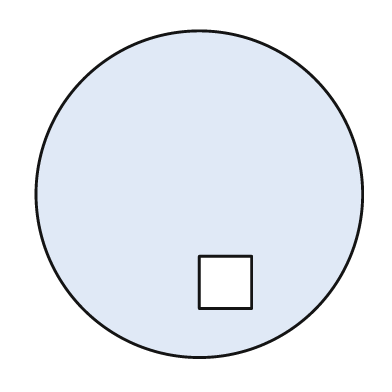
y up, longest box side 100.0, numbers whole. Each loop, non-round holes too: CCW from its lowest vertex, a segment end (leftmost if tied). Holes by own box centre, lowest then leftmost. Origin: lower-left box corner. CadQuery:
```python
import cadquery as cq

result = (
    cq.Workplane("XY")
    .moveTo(50.0, 50.0)
    .circle(50.0)
    .moveTo(50.0, 15.0)
    .lineTo(66.0, 15.0)
    .lineTo(66.0, 31.0)
    .lineTo(50.0, 31.0)
    .close()
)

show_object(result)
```